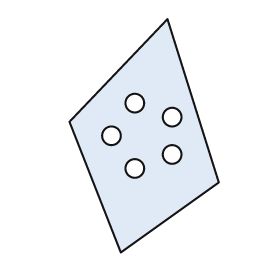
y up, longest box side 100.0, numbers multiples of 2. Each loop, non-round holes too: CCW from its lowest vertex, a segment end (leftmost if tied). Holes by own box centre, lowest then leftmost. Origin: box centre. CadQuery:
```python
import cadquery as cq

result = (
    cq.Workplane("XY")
    .moveTo(-10.0, -50.0)
    .lineTo(32.0, -20.0)
    .lineTo(10.0, 50.0)
    .lineTo(-32.0, 6.0)
    .close()
    .moveTo(-4.0, -14.0)
    .circle(4.0)
    .moveTo(12.0, -8.0)
    .circle(4.0)
    .moveTo(-14.0, 0.0)
    .circle(4.0)
    .moveTo(12.0, 8.0)
    .circle(4.0)
    .moveTo(-4.0, 14.0)
    .circle(4.0)
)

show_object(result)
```